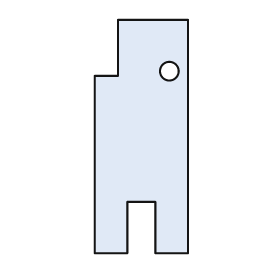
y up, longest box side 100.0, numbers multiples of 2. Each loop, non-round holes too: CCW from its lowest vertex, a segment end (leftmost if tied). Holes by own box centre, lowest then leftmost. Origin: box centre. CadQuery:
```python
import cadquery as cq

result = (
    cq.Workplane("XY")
    .moveTo(-20.0, -50.0)
    .lineTo(-6.0, -50.0)
    .lineTo(-6.0, -28.0)
    .lineTo(6.0, -28.0)
    .lineTo(6.0, -50.0)
    .lineTo(20.0, -50.0)
    .lineTo(20.0, 50.0)
    .lineTo(-10.0, 50.0)
    .lineTo(-10.0, 26.0)
    .lineTo(-20.0, 26.0)
    .close()
    .moveTo(12.0, 28.0)
    .circle(4.0)
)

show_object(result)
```